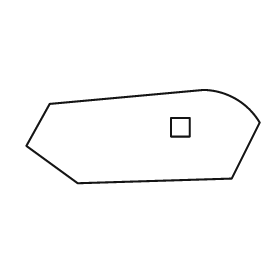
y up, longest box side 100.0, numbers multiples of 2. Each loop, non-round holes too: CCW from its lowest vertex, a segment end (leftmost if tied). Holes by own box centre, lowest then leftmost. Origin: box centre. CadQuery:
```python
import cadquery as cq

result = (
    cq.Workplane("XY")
    .moveTo(-28.0, -20.0)
    .lineTo(38.0, -18.0)
    .lineTo(50.0, 6.0)
    .threePointArc((40.0, 16.0), (26.0, 20.0))
    .lineTo(-40.0, 14.0)
    .lineTo(-50.0, -4.0)
    .close()
    .moveTo(12.0, 0.0)
    .lineTo(20.0, 0.0)
    .lineTo(20.0, 8.0)
    .lineTo(12.0, 8.0)
    .close()
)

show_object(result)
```